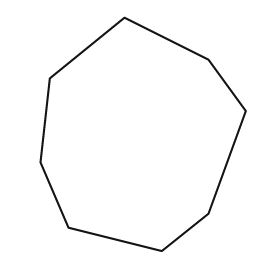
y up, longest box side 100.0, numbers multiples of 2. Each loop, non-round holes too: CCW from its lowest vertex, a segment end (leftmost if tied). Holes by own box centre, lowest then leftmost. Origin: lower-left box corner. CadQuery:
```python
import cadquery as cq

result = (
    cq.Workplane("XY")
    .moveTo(52.0, 0.0)
    .lineTo(72.0, 16.0)
    .lineTo(88.0, 60.0)
    .lineTo(72.0, 82.0)
    .lineTo(36.0, 100.0)
    .lineTo(4.0, 74.0)
    .lineTo(0.0, 38.0)
    .lineTo(12.0, 10.0)
    .close()
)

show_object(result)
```